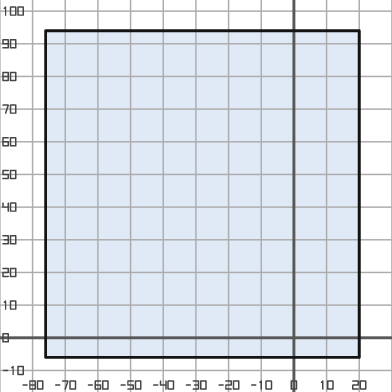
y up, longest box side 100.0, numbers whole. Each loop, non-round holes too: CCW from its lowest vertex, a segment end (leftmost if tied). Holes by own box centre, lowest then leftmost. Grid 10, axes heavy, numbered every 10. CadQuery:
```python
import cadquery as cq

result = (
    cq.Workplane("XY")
    .moveTo(-76.0, -6.0)
    .lineTo(20.0, -6.0)
    .lineTo(20.0, 94.0)
    .lineTo(-76.0, 94.0)
    .close()
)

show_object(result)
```